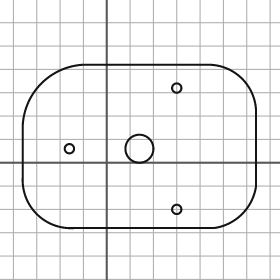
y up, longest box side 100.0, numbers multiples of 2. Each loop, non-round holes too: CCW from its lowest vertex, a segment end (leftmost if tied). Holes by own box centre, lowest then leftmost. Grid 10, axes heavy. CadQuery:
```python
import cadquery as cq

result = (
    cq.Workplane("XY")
    .moveTo(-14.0, -28.0)
    .lineTo(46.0, -28.0)
    .threePointArc((58.0, -22.0), (64.0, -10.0))
    .lineTo(64.0, 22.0)
    .threePointArc((58.0, 36.0), (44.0, 42.0))
    .lineTo(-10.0, 42.0)
    .threePointArc((-28.0, 34.0), (-36.0, 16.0))
    .lineTo(-36.0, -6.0)
    .threePointArc((-30.0, -22.0), (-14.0, -28.0))
    .close()
    .moveTo(30.0, -20.0)
    .circle(2.0)
    .moveTo(-16.0, 6.0)
    .circle(2.0)
    .moveTo(14.0, 6.0)
    .circle(6.0)
    .moveTo(30.0, 32.0)
    .circle(2.0)
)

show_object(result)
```